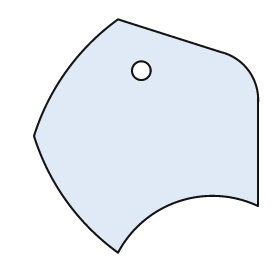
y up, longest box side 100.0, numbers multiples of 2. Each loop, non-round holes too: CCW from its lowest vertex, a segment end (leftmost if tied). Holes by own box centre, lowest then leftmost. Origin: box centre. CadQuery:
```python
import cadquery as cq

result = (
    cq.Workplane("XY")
    .moveTo(-12.0, -50.0)
    .threePointArc((14.0, -28.0), (48.0, -30.0))
    .lineTo(48.0, 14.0)
    .threePointArc((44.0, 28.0), (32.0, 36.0))
    .lineTo(-12.0, 50.0)
    .threePointArc((-34.0, 28.0), (-48.0, 0.0))
    .threePointArc((-34.0, -28.0), (-12.0, -50.0))
    .close()
    .moveTo(-2.0, 28.0)
    .circle(4.0)
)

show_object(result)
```